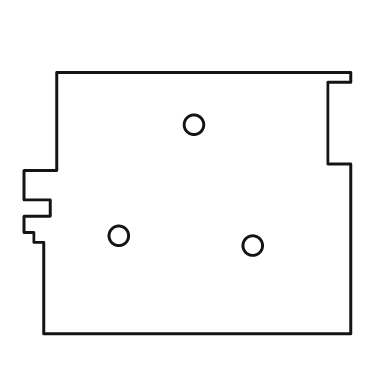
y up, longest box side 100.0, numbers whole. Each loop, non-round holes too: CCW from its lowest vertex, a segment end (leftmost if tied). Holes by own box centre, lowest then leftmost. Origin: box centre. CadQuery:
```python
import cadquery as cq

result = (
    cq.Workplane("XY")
    .moveTo(-44.0, -40.0)
    .lineTo(50.0, -40.0)
    .lineTo(50.0, 12.0)
    .lineTo(43.0, 12.0)
    .lineTo(43.0, 37.0)
    .lineTo(50.0, 37.0)
    .lineTo(50.0, 40.0)
    .lineTo(-40.0, 40.0)
    .lineTo(-40.0, 10.0)
    .lineTo(-50.0, 10.0)
    .lineTo(-50.0, 1.0)
    .lineTo(-42.0, 1.0)
    .lineTo(-42.0, -4.0)
    .lineTo(-50.0, -4.0)
    .lineTo(-50.0, -9.0)
    .lineTo(-47.0, -9.0)
    .lineTo(-47.0, -12.0)
    .lineTo(-44.0, -12.0)
    .close()
    .moveTo(20.0, -13.0)
    .circle(3.0)
    .moveTo(-21.0, -10.0)
    .circle(3.0)
    .moveTo(2.0, 24.0)
    .circle(3.0)
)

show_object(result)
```